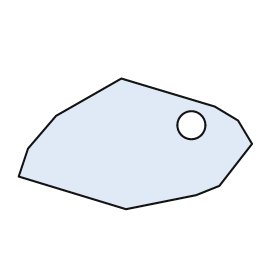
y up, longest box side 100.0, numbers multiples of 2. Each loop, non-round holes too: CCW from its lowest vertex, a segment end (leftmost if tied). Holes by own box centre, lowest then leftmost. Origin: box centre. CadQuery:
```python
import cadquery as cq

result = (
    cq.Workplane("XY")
    .moveTo(-4.0, -28.0)
    .lineTo(26.0, -22.0)
    .lineTo(36.0, -18.0)
    .lineTo(50.0, 0.0)
    .lineTo(44.0, 10.0)
    .lineTo(34.0, 16.0)
    .lineTo(-6.0, 28.0)
    .lineTo(-34.0, 12.0)
    .lineTo(-46.0, -2.0)
    .lineTo(-50.0, -14.0)
    .close()
    .moveTo(24.0, 8.0)
    .circle(6.0)
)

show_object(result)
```